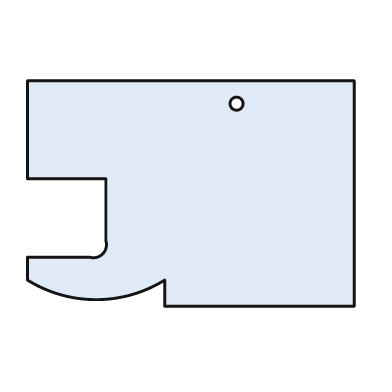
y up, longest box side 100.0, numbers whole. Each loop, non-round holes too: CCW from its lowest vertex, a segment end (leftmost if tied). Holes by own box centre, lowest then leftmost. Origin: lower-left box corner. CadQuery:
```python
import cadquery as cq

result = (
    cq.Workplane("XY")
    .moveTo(42.0, 0.0)
    .lineTo(100.0, 0.0)
    .lineTo(100.0, 69.0)
    .lineTo(0.0, 69.0)
    .lineTo(0.0, 39.0)
    .lineTo(24.0, 39.0)
    .lineTo(24.0, 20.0)
    .threePointArc((23.0, 16.0), (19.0, 15.0))
    .lineTo(0.0, 15.0)
    .lineTo(0.0, 8.0)
    .threePointArc((21.0, 2.0), (42.0, 8.0))
    .close()
    .moveTo(64.0, 62.0)
    .circle(2.0)
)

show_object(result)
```